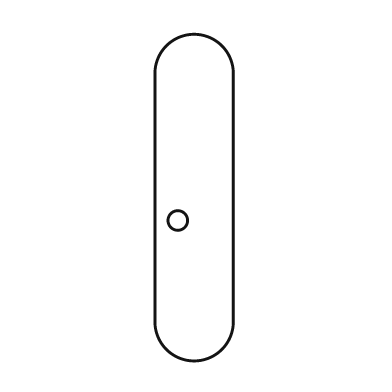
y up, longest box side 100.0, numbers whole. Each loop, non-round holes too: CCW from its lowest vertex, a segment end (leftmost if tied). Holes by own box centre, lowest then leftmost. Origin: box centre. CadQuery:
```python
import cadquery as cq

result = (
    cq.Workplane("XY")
    .moveTo(-12.0, -38.0)
    .threePointArc((0.0, -50.0), (12.0, -38.0))
    .lineTo(12.0, 38.0)
    .threePointArc((0.0, 50.0), (-12.0, 38.0))
    .close()
    .moveTo(-5.0, -7.0)
    .circle(3.0)
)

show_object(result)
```